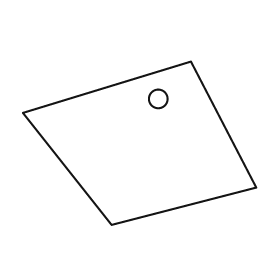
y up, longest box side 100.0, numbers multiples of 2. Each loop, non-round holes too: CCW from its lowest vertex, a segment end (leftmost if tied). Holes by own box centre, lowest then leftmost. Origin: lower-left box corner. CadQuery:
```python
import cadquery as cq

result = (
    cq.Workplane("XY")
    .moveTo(38.0, 0.0)
    .lineTo(100.0, 16.0)
    .lineTo(72.0, 70.0)
    .lineTo(0.0, 48.0)
    .close()
    .moveTo(58.0, 54.0)
    .circle(4.0)
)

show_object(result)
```